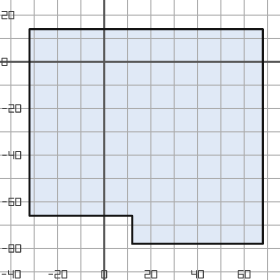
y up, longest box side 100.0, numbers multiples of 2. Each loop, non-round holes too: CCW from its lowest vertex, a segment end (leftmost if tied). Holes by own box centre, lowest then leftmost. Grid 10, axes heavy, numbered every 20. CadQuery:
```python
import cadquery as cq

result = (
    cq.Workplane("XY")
    .moveTo(12.0, -78.0)
    .lineTo(68.0, -78.0)
    .lineTo(68.0, 14.0)
    .lineTo(-32.0, 14.0)
    .lineTo(-32.0, -66.0)
    .lineTo(12.0, -66.0)
    .close()
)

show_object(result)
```